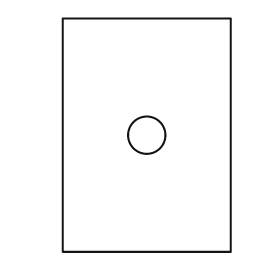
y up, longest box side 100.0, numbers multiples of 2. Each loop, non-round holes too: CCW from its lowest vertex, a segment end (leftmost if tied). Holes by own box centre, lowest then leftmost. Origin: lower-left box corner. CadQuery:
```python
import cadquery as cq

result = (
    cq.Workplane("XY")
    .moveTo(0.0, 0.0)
    .lineTo(72.0, 0.0)
    .lineTo(72.0, 100.0)
    .lineTo(0.0, 100.0)
    .close()
    .moveTo(36.0, 50.0)
    .circle(8.0)
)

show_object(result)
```